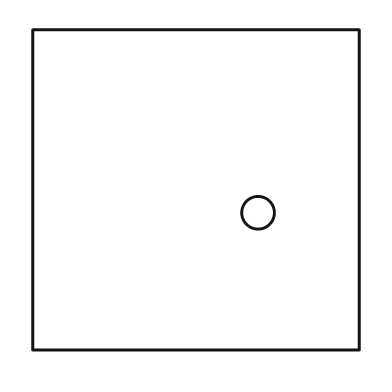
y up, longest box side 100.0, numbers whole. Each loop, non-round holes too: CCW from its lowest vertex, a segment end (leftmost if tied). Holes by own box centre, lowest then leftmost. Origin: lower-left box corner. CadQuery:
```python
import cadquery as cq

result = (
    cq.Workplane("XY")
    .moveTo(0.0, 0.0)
    .lineTo(100.0, 0.0)
    .lineTo(100.0, 98.0)
    .lineTo(0.0, 98.0)
    .close()
    .moveTo(69.0, 42.0)
    .circle(5.0)
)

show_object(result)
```